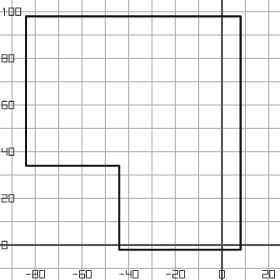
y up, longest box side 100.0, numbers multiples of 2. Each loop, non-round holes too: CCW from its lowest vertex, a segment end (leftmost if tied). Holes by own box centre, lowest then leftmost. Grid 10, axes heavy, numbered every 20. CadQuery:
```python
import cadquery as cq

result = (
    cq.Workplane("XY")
    .moveTo(-44.0, -2.0)
    .lineTo(8.0, -2.0)
    .lineTo(8.0, 98.0)
    .lineTo(-84.0, 98.0)
    .lineTo(-84.0, 34.0)
    .lineTo(-44.0, 34.0)
    .close()
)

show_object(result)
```